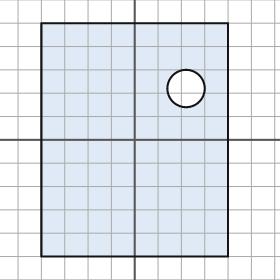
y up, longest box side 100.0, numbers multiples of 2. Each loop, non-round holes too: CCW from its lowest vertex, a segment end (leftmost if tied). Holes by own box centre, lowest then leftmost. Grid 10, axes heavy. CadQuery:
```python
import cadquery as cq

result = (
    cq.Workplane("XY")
    .moveTo(-40.0, -50.0)
    .lineTo(40.0, -50.0)
    .lineTo(40.0, 50.0)
    .lineTo(-40.0, 50.0)
    .close()
    .moveTo(22.0, 22.0)
    .circle(8.0)
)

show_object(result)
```